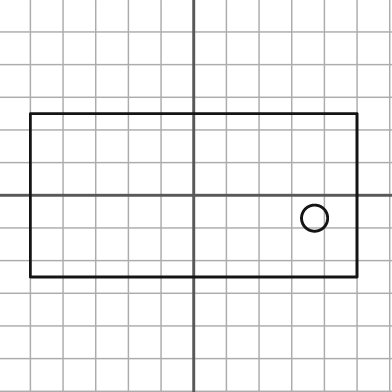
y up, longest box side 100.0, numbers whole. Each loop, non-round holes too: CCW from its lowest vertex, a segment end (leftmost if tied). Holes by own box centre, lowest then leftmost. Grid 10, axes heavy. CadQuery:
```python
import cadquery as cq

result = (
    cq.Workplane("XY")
    .moveTo(-50.0, -25.0)
    .lineTo(50.0, -25.0)
    .lineTo(50.0, 25.0)
    .lineTo(-50.0, 25.0)
    .close()
    .moveTo(37.0, -7.0)
    .circle(4.0)
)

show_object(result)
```